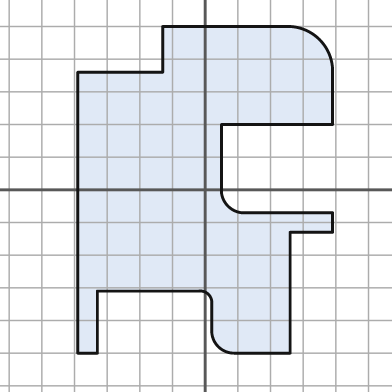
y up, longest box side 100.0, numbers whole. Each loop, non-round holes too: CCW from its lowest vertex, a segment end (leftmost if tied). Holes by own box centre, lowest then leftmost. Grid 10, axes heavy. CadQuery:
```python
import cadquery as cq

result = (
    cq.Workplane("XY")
    .moveTo(-39.0, -50.0)
    .lineTo(-33.0, -50.0)
    .lineTo(-33.0, -31.0)
    .lineTo(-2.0, -31.0)
    .threePointArc((1.0, -32.0), (2.0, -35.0))
    .lineTo(2.0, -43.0)
    .threePointArc((4.0, -48.0), (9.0, -50.0))
    .lineTo(26.0, -50.0)
    .lineTo(26.0, -13.0)
    .lineTo(39.0, -13.0)
    .lineTo(39.0, -7.0)
    .lineTo(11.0, -7.0)
    .threePointArc((7.0, -5.0), (5.0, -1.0))
    .lineTo(5.0, 20.0)
    .lineTo(39.0, 20.0)
    .lineTo(39.0, 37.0)
    .threePointArc((35.0, 46.0), (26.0, 50.0))
    .lineTo(-13.0, 50.0)
    .lineTo(-13.0, 36.0)
    .lineTo(-39.0, 36.0)
    .close()
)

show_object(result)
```